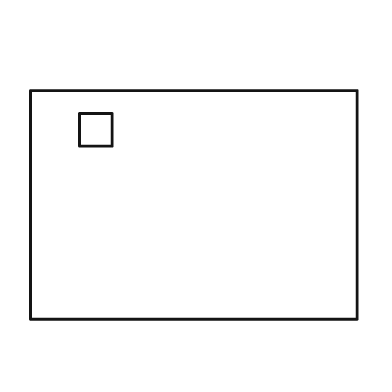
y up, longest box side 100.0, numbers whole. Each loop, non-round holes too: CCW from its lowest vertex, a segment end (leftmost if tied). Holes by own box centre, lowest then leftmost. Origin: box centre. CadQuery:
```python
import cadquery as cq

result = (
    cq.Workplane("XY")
    .moveTo(-50.0, -35.0)
    .lineTo(50.0, -35.0)
    .lineTo(50.0, 35.0)
    .lineTo(-50.0, 35.0)
    .close()
    .moveTo(-35.0, 18.0)
    .lineTo(-25.0, 18.0)
    .lineTo(-25.0, 28.0)
    .lineTo(-35.0, 28.0)
    .close()
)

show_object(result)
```